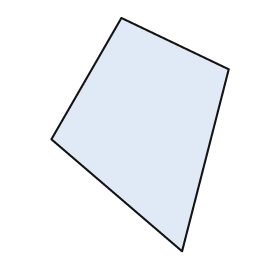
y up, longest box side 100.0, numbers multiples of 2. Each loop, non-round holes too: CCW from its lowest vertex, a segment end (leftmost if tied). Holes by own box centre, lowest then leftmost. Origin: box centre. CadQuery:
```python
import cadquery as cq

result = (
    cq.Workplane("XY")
    .moveTo(18.0, -50.0)
    .lineTo(38.0, 28.0)
    .lineTo(-8.0, 50.0)
    .lineTo(-38.0, -2.0)
    .close()
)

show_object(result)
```